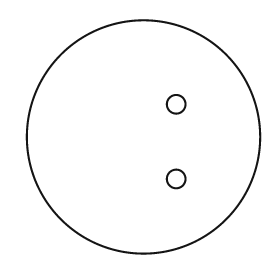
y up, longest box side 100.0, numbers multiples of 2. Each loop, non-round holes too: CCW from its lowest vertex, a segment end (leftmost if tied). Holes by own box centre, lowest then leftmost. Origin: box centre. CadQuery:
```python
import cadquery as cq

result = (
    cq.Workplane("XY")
    .moveTo(0.0, 0.0)
    .circle(50.0)
    .moveTo(14.0, -18.0)
    .circle(4.0)
    .moveTo(14.0, 14.0)
    .circle(4.0)
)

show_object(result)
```